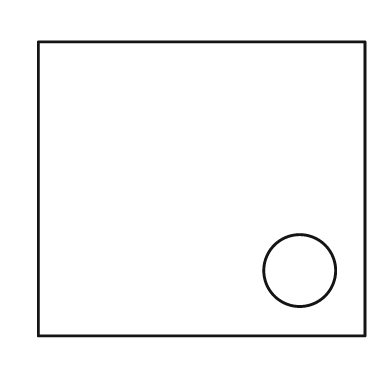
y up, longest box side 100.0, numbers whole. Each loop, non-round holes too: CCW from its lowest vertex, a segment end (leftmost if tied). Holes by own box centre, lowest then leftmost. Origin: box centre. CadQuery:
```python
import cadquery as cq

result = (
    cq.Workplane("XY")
    .moveTo(-50.0, -45.0)
    .lineTo(50.0, -45.0)
    .lineTo(50.0, 45.0)
    .lineTo(-50.0, 45.0)
    .close()
    .moveTo(30.0, -25.0)
    .circle(11.0)
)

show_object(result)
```